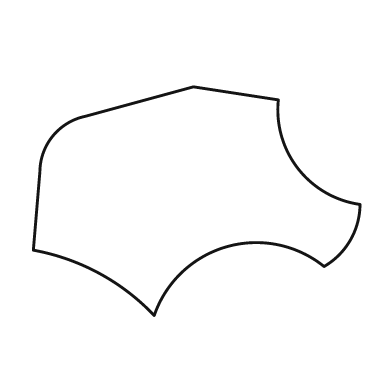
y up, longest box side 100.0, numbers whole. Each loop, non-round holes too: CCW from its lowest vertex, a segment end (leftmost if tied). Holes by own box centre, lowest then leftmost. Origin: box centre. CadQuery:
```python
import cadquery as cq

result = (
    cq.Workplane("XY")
    .moveTo(-13.0, -35.0)
    .threePointArc((9.0, -14.0), (39.0, -20.0))
    .threePointArc((47.0, -12.0), (50.0, -1.0))
    .threePointArc((31.0, 10.0), (25.0, 31.0))
    .lineTo(-1.0, 35.0)
    .lineTo(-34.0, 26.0)
    .threePointArc((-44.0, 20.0), (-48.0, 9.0))
    .lineTo(-50.0, -15.0)
    .threePointArc((-30.0, -22.0), (-13.0, -35.0))
    .close()
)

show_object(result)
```